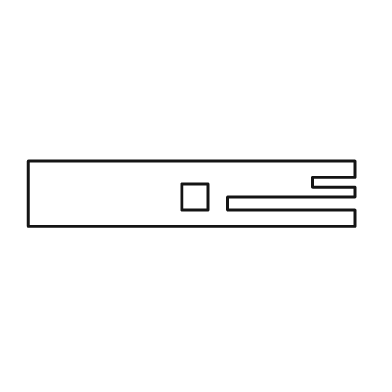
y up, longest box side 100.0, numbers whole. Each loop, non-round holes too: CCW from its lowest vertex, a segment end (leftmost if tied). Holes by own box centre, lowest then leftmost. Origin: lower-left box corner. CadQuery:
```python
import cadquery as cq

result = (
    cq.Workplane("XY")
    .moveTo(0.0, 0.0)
    .lineTo(100.0, 0.0)
    .lineTo(100.0, 5.0)
    .lineTo(61.0, 5.0)
    .lineTo(61.0, 9.0)
    .lineTo(100.0, 9.0)
    .lineTo(100.0, 12.0)
    .lineTo(87.0, 12.0)
    .lineTo(87.0, 15.0)
    .lineTo(100.0, 15.0)
    .lineTo(100.0, 20.0)
    .lineTo(0.0, 20.0)
    .close()
    .moveTo(47.0, 5.0)
    .lineTo(55.0, 5.0)
    .lineTo(55.0, 13.0)
    .lineTo(47.0, 13.0)
    .close()
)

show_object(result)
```